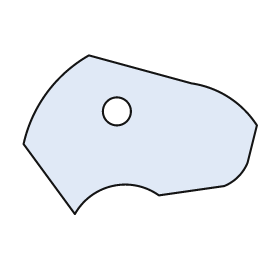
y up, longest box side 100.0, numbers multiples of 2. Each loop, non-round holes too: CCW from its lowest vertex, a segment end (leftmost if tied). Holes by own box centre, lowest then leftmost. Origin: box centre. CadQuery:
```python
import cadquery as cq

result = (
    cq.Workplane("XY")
    .moveTo(-28.0, -34.0)
    .threePointArc((-12.0, -22.0), (8.0, -26.0))
    .lineTo(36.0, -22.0)
    .threePointArc((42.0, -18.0), (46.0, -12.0))
    .lineTo(50.0, 4.0)
    .threePointArc((38.0, 16.0), (22.0, 22.0))
    .lineTo(-22.0, 34.0)
    .threePointArc((-40.0, 18.0), (-50.0, -4.0))
    .close()
    .moveTo(-10.0, 10.0)
    .circle(6.0)
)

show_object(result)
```